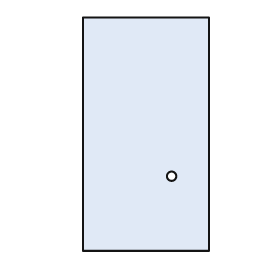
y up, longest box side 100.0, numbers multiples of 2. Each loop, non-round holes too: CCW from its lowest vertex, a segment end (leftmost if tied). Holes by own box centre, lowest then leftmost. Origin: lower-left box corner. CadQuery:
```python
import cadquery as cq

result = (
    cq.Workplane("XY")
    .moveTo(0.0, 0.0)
    .lineTo(54.0, 0.0)
    .lineTo(54.0, 100.0)
    .lineTo(0.0, 100.0)
    .close()
    .moveTo(38.0, 32.0)
    .circle(2.0)
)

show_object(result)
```